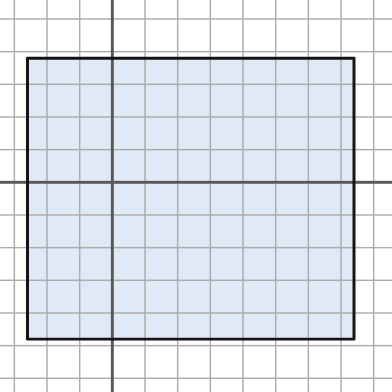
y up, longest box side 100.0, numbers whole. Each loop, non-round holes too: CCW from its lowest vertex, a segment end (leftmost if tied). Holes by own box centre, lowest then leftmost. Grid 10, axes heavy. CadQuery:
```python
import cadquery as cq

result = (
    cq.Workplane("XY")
    .moveTo(-26.0, -48.0)
    .lineTo(74.0, -48.0)
    .lineTo(74.0, 38.0)
    .lineTo(-26.0, 38.0)
    .close()
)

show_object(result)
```